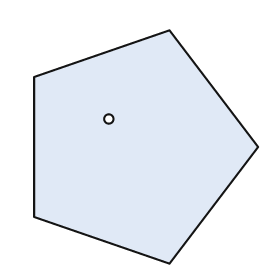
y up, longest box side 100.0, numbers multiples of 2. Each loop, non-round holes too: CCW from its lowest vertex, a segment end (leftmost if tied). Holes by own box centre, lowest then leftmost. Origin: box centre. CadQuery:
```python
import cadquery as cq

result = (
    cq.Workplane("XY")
    .moveTo(10.0, -50.0)
    .lineTo(48.0, 0.0)
    .lineTo(10.0, 50.0)
    .lineTo(-48.0, 30.0)
    .lineTo(-48.0, -30.0)
    .close()
    .moveTo(-16.0, 12.0)
    .circle(2.0)
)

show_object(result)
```